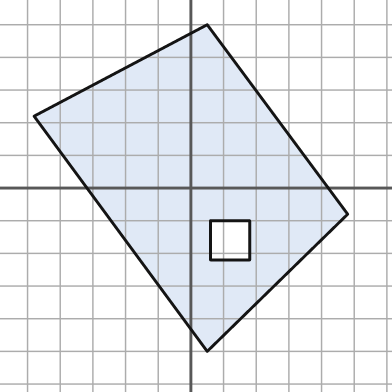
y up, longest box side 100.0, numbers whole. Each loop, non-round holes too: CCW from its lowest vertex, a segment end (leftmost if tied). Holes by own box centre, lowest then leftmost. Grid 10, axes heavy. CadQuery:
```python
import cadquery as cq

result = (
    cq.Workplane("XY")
    .moveTo(5.0, -50.0)
    .lineTo(48.0, -8.0)
    .lineTo(5.0, 50.0)
    .lineTo(-48.0, 22.0)
    .close()
    .moveTo(6.0, -22.0)
    .lineTo(18.0, -22.0)
    .lineTo(18.0, -10.0)
    .lineTo(6.0, -10.0)
    .close()
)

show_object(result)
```